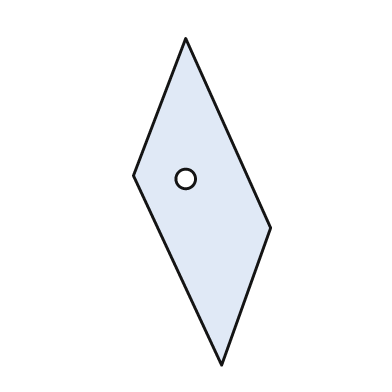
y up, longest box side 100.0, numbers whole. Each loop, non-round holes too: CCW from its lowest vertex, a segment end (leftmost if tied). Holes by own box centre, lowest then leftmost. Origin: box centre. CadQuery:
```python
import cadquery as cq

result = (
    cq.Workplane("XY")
    .moveTo(6.0, -50.0)
    .lineTo(21.0, -8.0)
    .lineTo(-5.0, 50.0)
    .lineTo(-21.0, 8.0)
    .close()
    .moveTo(-5.0, 7.0)
    .circle(3.0)
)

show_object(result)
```